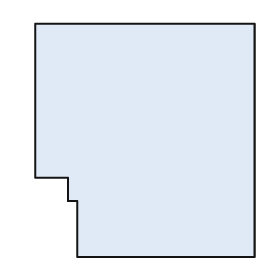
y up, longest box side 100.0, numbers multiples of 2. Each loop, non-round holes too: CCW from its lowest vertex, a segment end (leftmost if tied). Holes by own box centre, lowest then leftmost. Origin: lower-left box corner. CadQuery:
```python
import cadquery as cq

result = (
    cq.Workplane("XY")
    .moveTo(18.0, 0.0)
    .lineTo(94.0, 0.0)
    .lineTo(94.0, 100.0)
    .lineTo(0.0, 100.0)
    .lineTo(0.0, 34.0)
    .lineTo(14.0, 34.0)
    .lineTo(14.0, 24.0)
    .lineTo(18.0, 24.0)
    .close()
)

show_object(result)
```